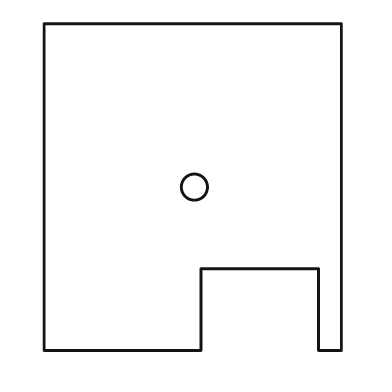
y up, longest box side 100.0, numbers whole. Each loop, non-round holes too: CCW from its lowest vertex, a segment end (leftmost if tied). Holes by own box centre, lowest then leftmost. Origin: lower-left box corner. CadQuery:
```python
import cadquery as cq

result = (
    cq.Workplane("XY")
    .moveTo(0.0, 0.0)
    .lineTo(48.0, 0.0)
    .lineTo(48.0, 25.0)
    .lineTo(84.0, 25.0)
    .lineTo(84.0, 0.0)
    .lineTo(91.0, 0.0)
    .lineTo(91.0, 100.0)
    .lineTo(0.0, 100.0)
    .close()
    .moveTo(46.0, 50.0)
    .circle(4.0)
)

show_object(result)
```